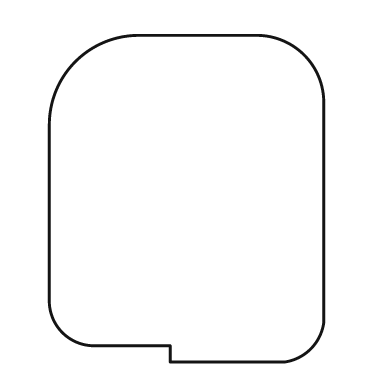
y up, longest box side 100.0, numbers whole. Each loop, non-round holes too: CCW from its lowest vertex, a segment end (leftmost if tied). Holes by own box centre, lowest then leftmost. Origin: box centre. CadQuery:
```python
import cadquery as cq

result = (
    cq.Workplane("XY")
    .moveTo(-5.0, -50.0)
    .lineTo(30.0, -50.0)
    .threePointArc((38.0, -46.0), (42.0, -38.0))
    .lineTo(42.0, 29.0)
    .threePointArc((36.0, 44.0), (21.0, 50.0))
    .lineTo(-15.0, 50.0)
    .threePointArc((-34.0, 42.0), (-42.0, 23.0))
    .lineTo(-42.0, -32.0)
    .threePointArc((-38.0, -41.0), (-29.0, -45.0))
    .lineTo(-5.0, -45.0)
    .close()
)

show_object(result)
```